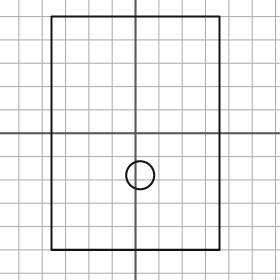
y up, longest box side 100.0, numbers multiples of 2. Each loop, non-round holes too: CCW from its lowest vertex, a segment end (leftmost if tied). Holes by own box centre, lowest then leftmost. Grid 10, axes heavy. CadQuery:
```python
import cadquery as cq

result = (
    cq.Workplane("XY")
    .moveTo(-36.0, -50.0)
    .lineTo(36.0, -50.0)
    .lineTo(36.0, 50.0)
    .lineTo(-36.0, 50.0)
    .close()
    .moveTo(2.0, -18.0)
    .circle(6.0)
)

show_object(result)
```